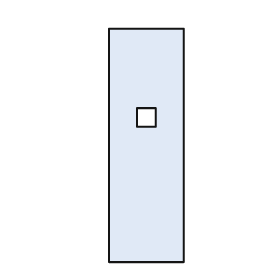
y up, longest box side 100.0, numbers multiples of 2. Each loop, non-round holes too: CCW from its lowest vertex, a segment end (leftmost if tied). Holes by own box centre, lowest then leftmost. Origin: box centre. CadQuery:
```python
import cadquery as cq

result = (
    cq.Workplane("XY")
    .moveTo(-16.0, -50.0)
    .lineTo(16.0, -50.0)
    .lineTo(16.0, 50.0)
    .lineTo(-16.0, 50.0)
    .close()
    .moveTo(-4.0, 8.0)
    .lineTo(4.0, 8.0)
    .lineTo(4.0, 16.0)
    .lineTo(-4.0, 16.0)
    .close()
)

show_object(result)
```